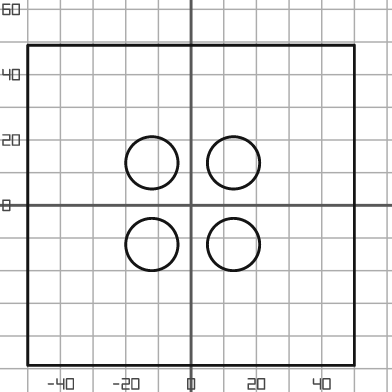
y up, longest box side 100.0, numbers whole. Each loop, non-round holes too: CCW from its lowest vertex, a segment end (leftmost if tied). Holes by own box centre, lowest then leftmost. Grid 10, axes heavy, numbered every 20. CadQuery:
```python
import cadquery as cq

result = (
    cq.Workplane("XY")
    .moveTo(-50.0, -49.0)
    .lineTo(50.0, -49.0)
    .lineTo(50.0, 49.0)
    .lineTo(-50.0, 49.0)
    .close()
    .moveTo(-12.0, -12.0)
    .circle(8.0)
    .moveTo(13.0, -12.0)
    .circle(8.0)
    .moveTo(-12.0, 13.0)
    .circle(8.0)
    .moveTo(13.0, 13.0)
    .circle(8.0)
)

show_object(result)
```